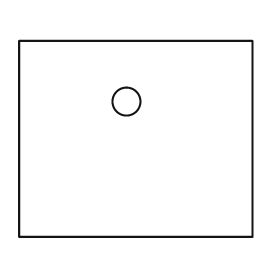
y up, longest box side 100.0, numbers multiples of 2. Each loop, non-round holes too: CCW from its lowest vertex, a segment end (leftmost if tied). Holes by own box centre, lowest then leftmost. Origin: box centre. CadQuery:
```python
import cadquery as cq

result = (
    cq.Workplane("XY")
    .moveTo(-50.0, -42.0)
    .lineTo(50.0, -42.0)
    .lineTo(50.0, 42.0)
    .lineTo(-50.0, 42.0)
    .close()
    .moveTo(-4.0, 16.0)
    .circle(6.0)
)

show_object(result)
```